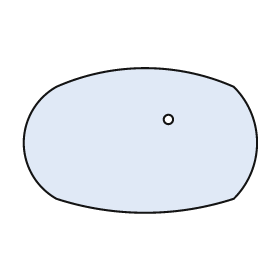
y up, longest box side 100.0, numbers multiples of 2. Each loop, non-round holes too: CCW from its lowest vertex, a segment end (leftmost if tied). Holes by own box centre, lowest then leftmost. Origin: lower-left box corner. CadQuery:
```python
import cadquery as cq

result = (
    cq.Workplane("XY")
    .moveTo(14.0, 6.0)
    .threePointArc((52.0, 0.0), (90.0, 6.0))
    .threePointArc((100.0, 30.0), (90.0, 54.0))
    .threePointArc((52.0, 62.0), (14.0, 54.0))
    .threePointArc((0.0, 30.0), (14.0, 6.0))
    .close()
    .moveTo(62.0, 40.0)
    .circle(2.0)
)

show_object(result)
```